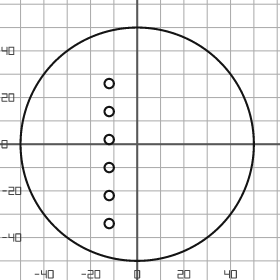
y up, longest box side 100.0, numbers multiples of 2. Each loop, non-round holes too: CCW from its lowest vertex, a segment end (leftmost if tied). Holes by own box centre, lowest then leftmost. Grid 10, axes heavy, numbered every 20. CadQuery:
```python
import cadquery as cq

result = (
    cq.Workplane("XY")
    .moveTo(0.0, 0.0)
    .circle(50.0)
    .moveTo(-12.0, -34.0)
    .circle(2.0)
    .moveTo(-12.0, -22.0)
    .circle(2.0)
    .moveTo(-12.0, -10.0)
    .circle(2.0)
    .moveTo(-12.0, 2.0)
    .circle(2.0)
    .moveTo(-12.0, 14.0)
    .circle(2.0)
    .moveTo(-12.0, 26.0)
    .circle(2.0)
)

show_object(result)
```